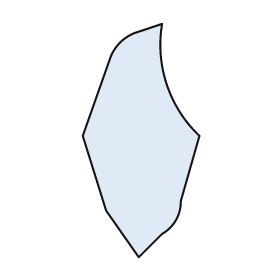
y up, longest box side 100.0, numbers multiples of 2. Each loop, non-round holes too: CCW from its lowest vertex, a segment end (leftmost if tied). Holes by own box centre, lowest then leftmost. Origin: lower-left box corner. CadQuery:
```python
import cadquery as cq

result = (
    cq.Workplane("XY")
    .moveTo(24.0, 0.0)
    .lineTo(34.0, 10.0)
    .threePointArc((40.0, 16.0), (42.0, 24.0))
    .lineTo(50.0, 52.0)
    .threePointArc((36.0, 74.0), (34.0, 100.0))
    .lineTo(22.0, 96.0)
    .threePointArc((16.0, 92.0), (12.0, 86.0))
    .lineTo(0.0, 52.0)
    .lineTo(10.0, 20.0)
    .close()
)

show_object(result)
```